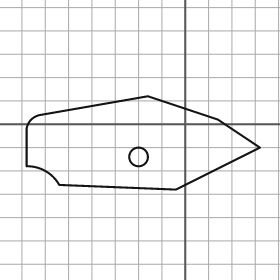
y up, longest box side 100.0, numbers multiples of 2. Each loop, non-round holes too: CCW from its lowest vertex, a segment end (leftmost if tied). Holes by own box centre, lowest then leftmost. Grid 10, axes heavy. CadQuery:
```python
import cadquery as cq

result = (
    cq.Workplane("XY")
    .moveTo(-4.0, -28.0)
    .lineTo(32.0, -10.0)
    .lineTo(14.0, 2.0)
    .lineTo(-16.0, 12.0)
    .lineTo(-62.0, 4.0)
    .threePointArc((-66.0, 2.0), (-68.0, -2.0))
    .lineTo(-68.0, -18.0)
    .threePointArc((-60.0, -20.0), (-54.0, -26.0))
    .close()
    .moveTo(-20.0, -14.0)
    .circle(4.0)
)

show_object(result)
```